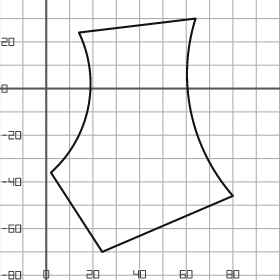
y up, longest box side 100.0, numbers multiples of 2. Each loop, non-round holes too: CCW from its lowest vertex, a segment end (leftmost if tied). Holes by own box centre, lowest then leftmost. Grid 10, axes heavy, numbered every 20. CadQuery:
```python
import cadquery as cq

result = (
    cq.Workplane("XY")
    .moveTo(24.0, -70.0)
    .lineTo(80.0, -46.0)
    .threePointArc((62.0, -10.0), (64.0, 30.0))
    .lineTo(14.0, 24.0)
    .threePointArc((18.0, -8.0), (2.0, -36.0))
    .close()
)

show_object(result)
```